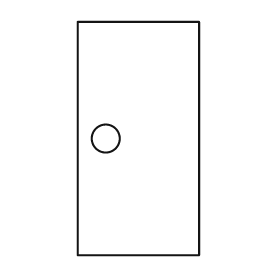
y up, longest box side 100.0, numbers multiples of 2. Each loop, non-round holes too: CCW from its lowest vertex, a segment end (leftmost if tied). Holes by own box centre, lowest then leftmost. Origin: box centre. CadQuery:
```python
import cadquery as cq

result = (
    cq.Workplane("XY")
    .moveTo(-26.0, -50.0)
    .lineTo(26.0, -50.0)
    .lineTo(26.0, 50.0)
    .lineTo(-26.0, 50.0)
    .close()
    .moveTo(-14.0, 0.0)
    .circle(6.0)
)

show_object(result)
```